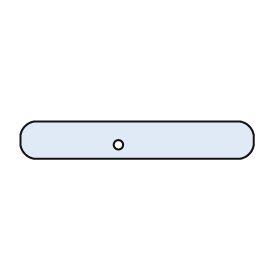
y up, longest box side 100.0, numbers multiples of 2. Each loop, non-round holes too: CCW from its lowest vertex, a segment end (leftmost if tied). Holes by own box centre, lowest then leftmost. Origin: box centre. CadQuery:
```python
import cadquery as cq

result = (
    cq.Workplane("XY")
    .moveTo(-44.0, -8.0)
    .lineTo(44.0, -8.0)
    .threePointArc((48.0, -6.0), (50.0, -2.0))
    .lineTo(50.0, 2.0)
    .threePointArc((48.0, 6.0), (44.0, 8.0))
    .lineTo(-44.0, 8.0)
    .threePointArc((-48.0, 6.0), (-50.0, 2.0))
    .lineTo(-50.0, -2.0)
    .threePointArc((-48.0, -6.0), (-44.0, -8.0))
    .close()
    .moveTo(-8.0, -2.0)
    .circle(2.0)
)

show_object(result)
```